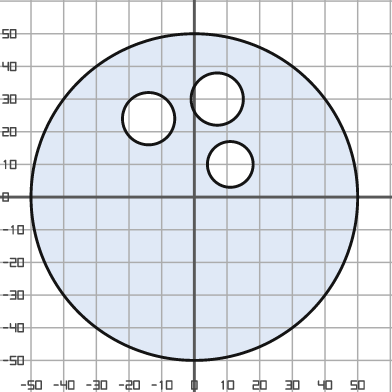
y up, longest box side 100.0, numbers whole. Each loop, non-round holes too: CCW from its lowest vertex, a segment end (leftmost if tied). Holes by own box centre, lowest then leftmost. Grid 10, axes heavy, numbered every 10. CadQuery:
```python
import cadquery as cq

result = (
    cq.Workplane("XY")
    .moveTo(0.0, 0.0)
    .circle(50.0)
    .moveTo(11.0, 10.0)
    .circle(7.0)
    .moveTo(-14.0, 24.0)
    .circle(8.0)
    .moveTo(7.0, 30.0)
    .circle(8.0)
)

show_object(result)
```